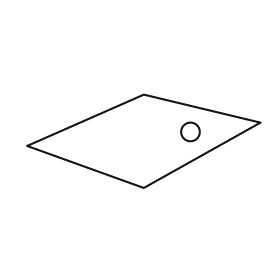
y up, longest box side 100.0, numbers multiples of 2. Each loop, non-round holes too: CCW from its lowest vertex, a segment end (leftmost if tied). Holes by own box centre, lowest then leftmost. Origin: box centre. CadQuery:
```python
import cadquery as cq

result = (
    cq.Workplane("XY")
    .moveTo(0.0, -20.0)
    .lineTo(50.0, 8.0)
    .lineTo(0.0, 20.0)
    .lineTo(-50.0, -2.0)
    .close()
    .moveTo(20.0, 4.0)
    .circle(4.0)
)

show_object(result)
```